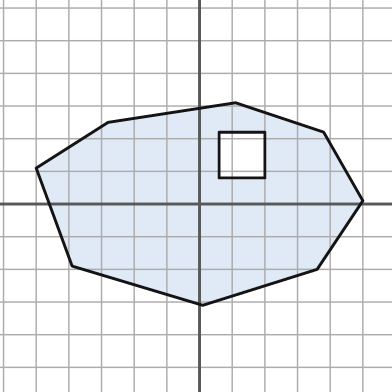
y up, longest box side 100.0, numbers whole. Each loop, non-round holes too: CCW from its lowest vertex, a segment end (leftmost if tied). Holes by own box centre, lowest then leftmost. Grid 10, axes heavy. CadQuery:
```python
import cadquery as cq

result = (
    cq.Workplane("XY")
    .moveTo(1.0, -31.0)
    .lineTo(36.0, -20.0)
    .lineTo(50.0, 1.0)
    .lineTo(38.0, 22.0)
    .lineTo(11.0, 31.0)
    .lineTo(-28.0, 25.0)
    .lineTo(-50.0, 11.0)
    .lineTo(-39.0, -19.0)
    .close()
    .moveTo(6.0, 8.0)
    .lineTo(20.0, 8.0)
    .lineTo(20.0, 22.0)
    .lineTo(6.0, 22.0)
    .close()
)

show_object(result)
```